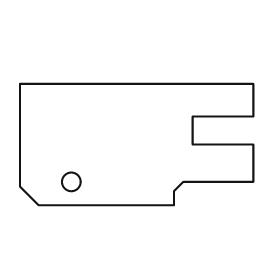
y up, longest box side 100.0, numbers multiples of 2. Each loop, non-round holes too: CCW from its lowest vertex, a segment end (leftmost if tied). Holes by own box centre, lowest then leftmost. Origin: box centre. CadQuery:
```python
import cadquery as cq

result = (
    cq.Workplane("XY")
    .moveTo(-42.0, -26.0)
    .lineTo(16.0, -26.0)
    .lineTo(16.0, -20.0)
    .lineTo(20.0, -16.0)
    .lineTo(50.0, -16.0)
    .lineTo(50.0, 0.0)
    .lineTo(24.0, 0.0)
    .lineTo(24.0, 12.0)
    .lineTo(50.0, 12.0)
    .lineTo(50.0, 26.0)
    .lineTo(-50.0, 26.0)
    .lineTo(-50.0, -18.0)
    .close()
    .moveTo(-28.0, -16.0)
    .circle(4.0)
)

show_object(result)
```